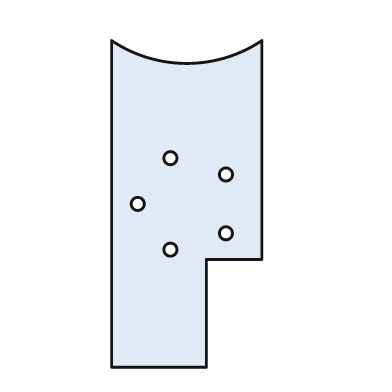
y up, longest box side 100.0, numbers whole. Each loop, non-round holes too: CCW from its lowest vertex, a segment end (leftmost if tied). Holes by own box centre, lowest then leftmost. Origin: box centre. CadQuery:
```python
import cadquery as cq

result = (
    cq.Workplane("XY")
    .moveTo(-23.0, -50.0)
    .lineTo(6.0, -50.0)
    .lineTo(6.0, -17.0)
    .lineTo(23.0, -17.0)
    .lineTo(23.0, 50.0)
    .threePointArc((0.0, 43.0), (-23.0, 50.0))
    .close()
    .moveTo(-5.0, -14.0)
    .circle(2.0)
    .moveTo(12.0, -9.0)
    .circle(2.0)
    .moveTo(-15.0, 0.0)
    .circle(2.0)
    .moveTo(12.0, 9.0)
    .circle(2.0)
    .moveTo(-5.0, 14.0)
    .circle(2.0)
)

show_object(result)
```